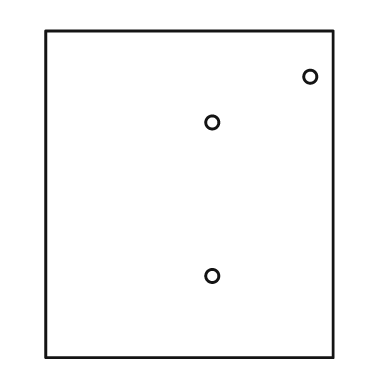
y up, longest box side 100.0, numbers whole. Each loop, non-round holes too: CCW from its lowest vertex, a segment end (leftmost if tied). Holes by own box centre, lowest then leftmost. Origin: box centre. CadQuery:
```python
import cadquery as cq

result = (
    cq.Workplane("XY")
    .moveTo(-44.0, -50.0)
    .lineTo(44.0, -50.0)
    .lineTo(44.0, 50.0)
    .lineTo(-44.0, 50.0)
    .close()
    .moveTo(7.0, -25.0)
    .circle(2.0)
    .moveTo(7.0, 22.0)
    .circle(2.0)
    .moveTo(37.0, 36.0)
    .circle(2.0)
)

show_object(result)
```